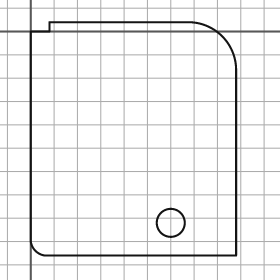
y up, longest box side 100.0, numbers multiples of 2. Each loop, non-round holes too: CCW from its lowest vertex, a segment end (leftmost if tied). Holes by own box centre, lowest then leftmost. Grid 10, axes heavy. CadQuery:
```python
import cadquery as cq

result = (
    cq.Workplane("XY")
    .moveTo(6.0, -96.0)
    .lineTo(88.0, -96.0)
    .lineTo(88.0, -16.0)
    .threePointArc((82.0, -2.0), (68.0, 4.0))
    .lineTo(8.0, 4.0)
    .lineTo(8.0, 0.0)
    .lineTo(0.0, 0.0)
    .lineTo(0.0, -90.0)
    .threePointArc((2.0, -94.0), (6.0, -96.0))
    .close()
    .moveTo(60.0, -82.0)
    .circle(6.0)
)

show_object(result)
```